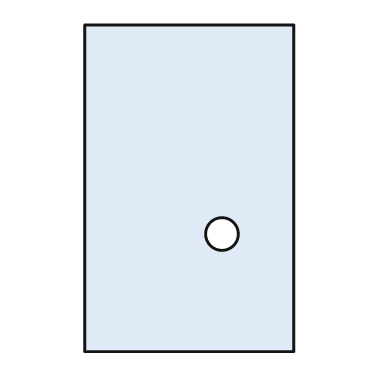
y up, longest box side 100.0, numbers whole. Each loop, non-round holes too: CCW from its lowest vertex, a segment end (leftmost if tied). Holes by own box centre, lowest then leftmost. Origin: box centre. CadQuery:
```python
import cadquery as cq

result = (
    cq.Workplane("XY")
    .moveTo(-32.0, -50.0)
    .lineTo(32.0, -50.0)
    .lineTo(32.0, 50.0)
    .lineTo(-32.0, 50.0)
    .close()
    .moveTo(10.0, -14.0)
    .circle(5.0)
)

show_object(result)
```